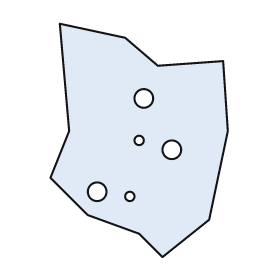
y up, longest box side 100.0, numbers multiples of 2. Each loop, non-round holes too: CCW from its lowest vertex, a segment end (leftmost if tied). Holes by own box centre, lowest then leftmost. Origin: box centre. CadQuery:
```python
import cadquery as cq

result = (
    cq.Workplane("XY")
    .moveTo(10.0, -50.0)
    .lineTo(30.0, -34.0)
    .lineTo(38.0, 4.0)
    .lineTo(36.0, 34.0)
    .lineTo(8.0, 32.0)
    .lineTo(-6.0, 44.0)
    .lineTo(-34.0, 50.0)
    .lineTo(-30.0, 4.0)
    .lineTo(-38.0, -16.0)
    .lineTo(-22.0, -32.0)
    .lineTo(0.0, -40.0)
    .close()
    .moveTo(-4.0, -24.0)
    .circle(2.0)
    .moveTo(-18.0, -22.0)
    .circle(4.0)
    .moveTo(14.0, -4.0)
    .circle(4.0)
    .moveTo(0.0, 0.0)
    .circle(2.0)
    .moveTo(2.0, 18.0)
    .circle(4.0)
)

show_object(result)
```